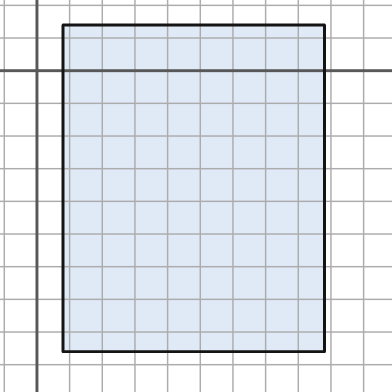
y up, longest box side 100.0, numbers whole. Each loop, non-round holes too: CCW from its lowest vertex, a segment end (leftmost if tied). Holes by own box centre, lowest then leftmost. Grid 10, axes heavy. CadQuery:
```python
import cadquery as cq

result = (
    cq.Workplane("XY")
    .moveTo(8.0, -86.0)
    .lineTo(88.0, -86.0)
    .lineTo(88.0, 14.0)
    .lineTo(8.0, 14.0)
    .close()
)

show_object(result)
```